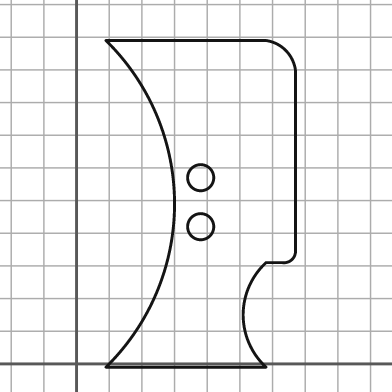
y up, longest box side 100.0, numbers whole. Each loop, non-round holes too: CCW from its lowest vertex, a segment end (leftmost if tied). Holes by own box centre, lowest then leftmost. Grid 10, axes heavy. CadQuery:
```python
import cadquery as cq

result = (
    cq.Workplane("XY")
    .moveTo(9.0, -1.0)
    .lineTo(58.0, -1.0)
    .threePointArc((51.0, 15.0), (58.0, 31.0))
    .lineTo(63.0, 31.0)
    .threePointArc((66.0, 32.0), (67.0, 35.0))
    .lineTo(67.0, 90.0)
    .threePointArc((64.0, 96.0), (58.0, 99.0))
    .lineTo(9.0, 99.0)
    .threePointArc((30.0, 49.0), (9.0, -1.0))
    .close()
    .moveTo(38.0, 42.0)
    .circle(4.0)
    .moveTo(38.0, 57.0)
    .circle(4.0)
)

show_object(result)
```